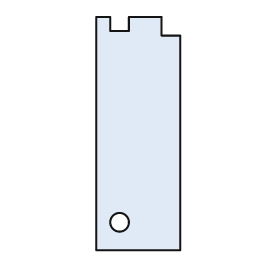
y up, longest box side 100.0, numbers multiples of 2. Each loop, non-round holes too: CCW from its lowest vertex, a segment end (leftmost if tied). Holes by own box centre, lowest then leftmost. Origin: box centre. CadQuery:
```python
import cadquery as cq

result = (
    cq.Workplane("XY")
    .moveTo(-18.0, -50.0)
    .lineTo(18.0, -50.0)
    .lineTo(18.0, 42.0)
    .lineTo(10.0, 42.0)
    .lineTo(10.0, 50.0)
    .lineTo(-4.0, 50.0)
    .lineTo(-4.0, 44.0)
    .lineTo(-12.0, 44.0)
    .lineTo(-12.0, 50.0)
    .lineTo(-18.0, 50.0)
    .close()
    .moveTo(-8.0, -38.0)
    .circle(4.0)
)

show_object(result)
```